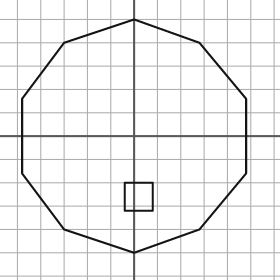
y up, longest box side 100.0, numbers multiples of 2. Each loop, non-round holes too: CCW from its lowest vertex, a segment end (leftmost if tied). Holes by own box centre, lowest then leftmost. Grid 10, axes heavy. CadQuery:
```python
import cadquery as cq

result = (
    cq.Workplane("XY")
    .moveTo(0.0, -50.0)
    .lineTo(28.0, -40.0)
    .lineTo(48.0, -16.0)
    .lineTo(48.0, 16.0)
    .lineTo(28.0, 40.0)
    .lineTo(0.0, 50.0)
    .lineTo(-30.0, 40.0)
    .lineTo(-48.0, 16.0)
    .lineTo(-48.0, -16.0)
    .lineTo(-30.0, -40.0)
    .close()
    .moveTo(-4.0, -32.0)
    .lineTo(8.0, -32.0)
    .lineTo(8.0, -20.0)
    .lineTo(-4.0, -20.0)
    .close()
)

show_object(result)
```